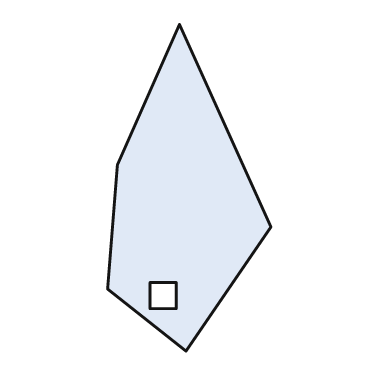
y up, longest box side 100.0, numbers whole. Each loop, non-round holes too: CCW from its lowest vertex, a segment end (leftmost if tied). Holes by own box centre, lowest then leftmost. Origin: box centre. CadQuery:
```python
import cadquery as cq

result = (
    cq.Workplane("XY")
    .moveTo(-1.0, -50.0)
    .lineTo(25.0, -12.0)
    .lineTo(-3.0, 50.0)
    .lineTo(-22.0, 7.0)
    .lineTo(-25.0, -31.0)
    .close()
    .moveTo(-12.0, -37.0)
    .lineTo(-4.0, -37.0)
    .lineTo(-4.0, -29.0)
    .lineTo(-12.0, -29.0)
    .close()
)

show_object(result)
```